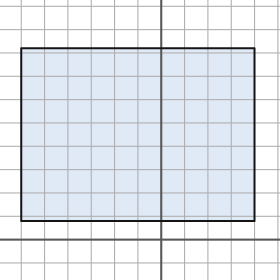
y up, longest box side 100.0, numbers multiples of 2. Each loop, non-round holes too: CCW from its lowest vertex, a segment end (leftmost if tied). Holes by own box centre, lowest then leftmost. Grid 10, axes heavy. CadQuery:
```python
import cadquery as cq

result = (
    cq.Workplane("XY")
    .moveTo(-60.0, 8.0)
    .lineTo(40.0, 8.0)
    .lineTo(40.0, 82.0)
    .lineTo(-60.0, 82.0)
    .close()
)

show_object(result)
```